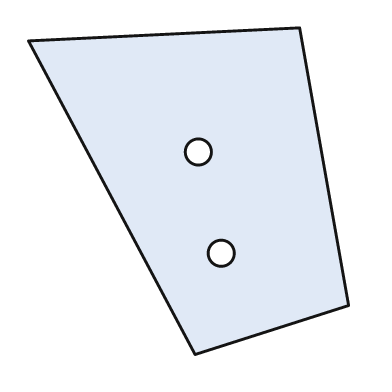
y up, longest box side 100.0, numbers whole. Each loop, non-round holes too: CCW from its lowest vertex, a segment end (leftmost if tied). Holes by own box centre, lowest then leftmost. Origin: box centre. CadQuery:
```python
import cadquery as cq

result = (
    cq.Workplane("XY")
    .moveTo(2.0, -50.0)
    .lineTo(49.0, -35.0)
    .lineTo(34.0, 50.0)
    .lineTo(-49.0, 46.0)
    .close()
    .moveTo(10.0, -19.0)
    .circle(4.0)
    .moveTo(3.0, 12.0)
    .circle(4.0)
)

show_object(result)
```